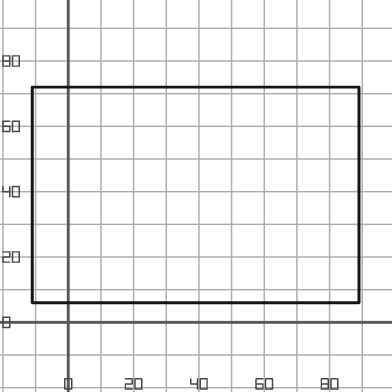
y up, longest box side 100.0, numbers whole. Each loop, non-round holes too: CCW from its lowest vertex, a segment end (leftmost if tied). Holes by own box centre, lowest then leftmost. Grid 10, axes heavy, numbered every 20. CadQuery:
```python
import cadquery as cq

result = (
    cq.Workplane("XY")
    .moveTo(-11.0, 6.0)
    .lineTo(89.0, 6.0)
    .lineTo(89.0, 72.0)
    .lineTo(-11.0, 72.0)
    .close()
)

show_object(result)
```